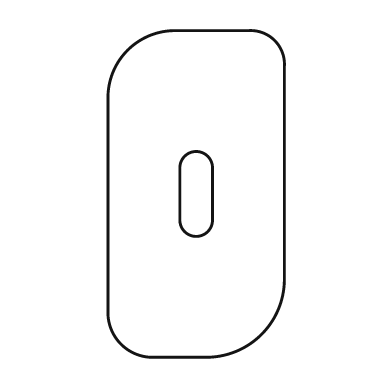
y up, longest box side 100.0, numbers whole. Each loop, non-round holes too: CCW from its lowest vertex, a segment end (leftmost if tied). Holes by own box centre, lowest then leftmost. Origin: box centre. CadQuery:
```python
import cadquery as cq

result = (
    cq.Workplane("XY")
    .moveTo(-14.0, -50.0)
    .lineTo(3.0, -50.0)
    .threePointArc((20.0, -43.0), (27.0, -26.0))
    .lineTo(27.0, 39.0)
    .threePointArc((24.0, 47.0), (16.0, 50.0))
    .lineTo(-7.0, 50.0)
    .threePointArc((-21.0, 44.0), (-27.0, 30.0))
    .lineTo(-27.0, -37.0)
    .threePointArc((-23.0, -46.0), (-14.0, -50.0))
    .close()
    .moveTo(-5.0, -8.0)
    .threePointArc((0.0, -13.0), (5.0, -8.0))
    .lineTo(5.0, 8.0)
    .threePointArc((0.0, 13.0), (-5.0, 8.0))
    .close()
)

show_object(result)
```